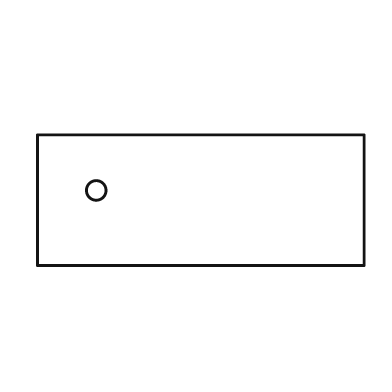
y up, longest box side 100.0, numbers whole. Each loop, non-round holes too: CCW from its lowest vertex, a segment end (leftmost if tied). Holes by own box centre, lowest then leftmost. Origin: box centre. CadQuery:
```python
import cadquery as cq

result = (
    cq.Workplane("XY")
    .moveTo(-50.0, -20.0)
    .lineTo(50.0, -20.0)
    .lineTo(50.0, 20.0)
    .lineTo(-50.0, 20.0)
    .close()
    .moveTo(-32.0, 3.0)
    .circle(3.0)
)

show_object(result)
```